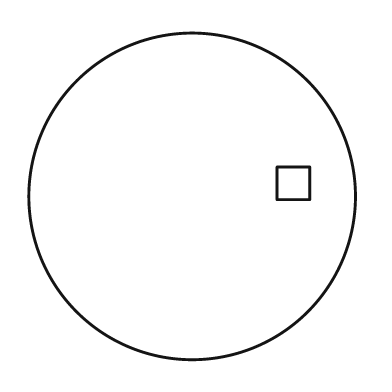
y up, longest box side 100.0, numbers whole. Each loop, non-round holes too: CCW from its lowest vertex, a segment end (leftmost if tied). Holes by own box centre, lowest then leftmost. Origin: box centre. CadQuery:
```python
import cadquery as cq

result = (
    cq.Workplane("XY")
    .moveTo(0.0, 0.0)
    .circle(50.0)
    .moveTo(26.0, -1.0)
    .lineTo(36.0, -1.0)
    .lineTo(36.0, 9.0)
    .lineTo(26.0, 9.0)
    .close()
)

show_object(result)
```